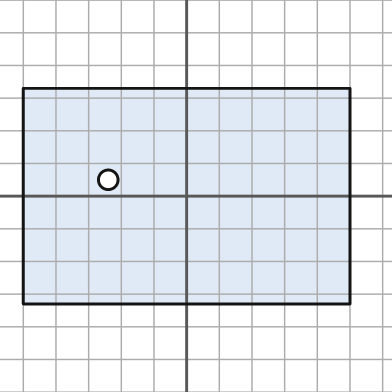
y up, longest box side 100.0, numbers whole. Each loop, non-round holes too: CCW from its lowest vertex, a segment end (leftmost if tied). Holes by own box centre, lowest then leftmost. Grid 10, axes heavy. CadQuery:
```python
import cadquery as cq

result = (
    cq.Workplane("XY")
    .moveTo(-50.0, -33.0)
    .lineTo(50.0, -33.0)
    .lineTo(50.0, 33.0)
    .lineTo(-50.0, 33.0)
    .close()
    .moveTo(-24.0, 5.0)
    .circle(3.0)
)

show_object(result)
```